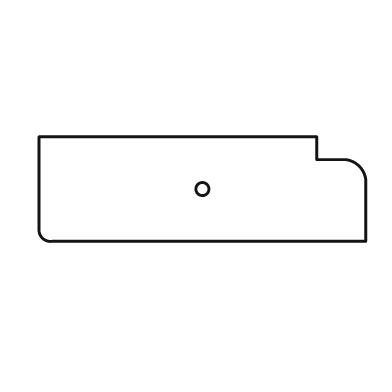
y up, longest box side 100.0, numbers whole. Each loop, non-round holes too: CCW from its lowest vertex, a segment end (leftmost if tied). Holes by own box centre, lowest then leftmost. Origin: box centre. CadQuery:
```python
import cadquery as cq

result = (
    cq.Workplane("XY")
    .moveTo(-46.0, -16.0)
    .lineTo(50.0, -16.0)
    .lineTo(50.0, 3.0)
    .threePointArc((48.0, 7.0), (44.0, 9.0))
    .lineTo(35.0, 9.0)
    .lineTo(35.0, 16.0)
    .lineTo(-50.0, 16.0)
    .lineTo(-50.0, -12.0)
    .threePointArc((-49.0, -15.0), (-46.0, -16.0))
    .close()
    .moveTo(0.0, 0.0)
    .circle(2.0)
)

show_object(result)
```